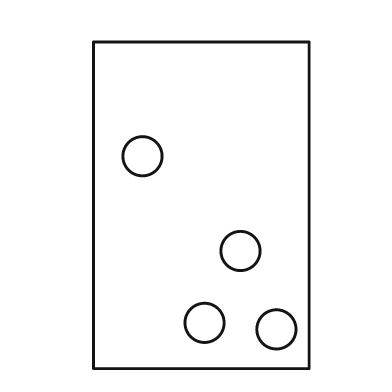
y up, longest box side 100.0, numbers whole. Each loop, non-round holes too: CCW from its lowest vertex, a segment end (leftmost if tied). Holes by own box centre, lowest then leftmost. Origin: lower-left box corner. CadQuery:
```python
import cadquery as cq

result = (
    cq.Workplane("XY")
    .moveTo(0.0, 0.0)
    .lineTo(66.0, 0.0)
    .lineTo(66.0, 100.0)
    .lineTo(0.0, 100.0)
    .close()
    .moveTo(56.0, 12.0)
    .circle(6.0)
    .moveTo(34.0, 14.0)
    .circle(6.0)
    .moveTo(45.0, 36.0)
    .circle(6.0)
    .moveTo(15.0, 65.0)
    .circle(6.0)
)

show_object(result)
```